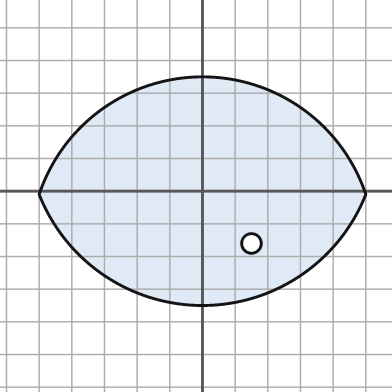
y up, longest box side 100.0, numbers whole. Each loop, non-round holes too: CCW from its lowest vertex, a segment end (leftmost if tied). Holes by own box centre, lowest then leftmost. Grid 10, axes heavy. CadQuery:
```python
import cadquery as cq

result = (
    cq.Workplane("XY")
    .moveTo(-50.0, -1.0)
    .threePointArc((0.0, -35.0), (50.0, -1.0))
    .threePointArc((0.0, 35.0), (-50.0, -1.0))
    .close()
    .moveTo(15.0, -16.0)
    .circle(3.0)
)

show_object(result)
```